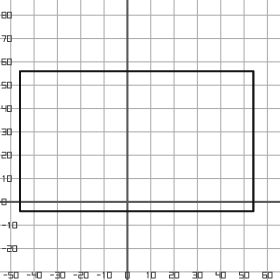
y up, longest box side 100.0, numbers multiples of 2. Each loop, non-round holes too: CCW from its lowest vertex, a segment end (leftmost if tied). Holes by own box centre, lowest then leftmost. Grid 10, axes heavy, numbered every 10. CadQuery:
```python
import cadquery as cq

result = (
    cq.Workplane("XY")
    .moveTo(-46.0, -4.0)
    .lineTo(54.0, -4.0)
    .lineTo(54.0, 56.0)
    .lineTo(-46.0, 56.0)
    .close()
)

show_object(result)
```